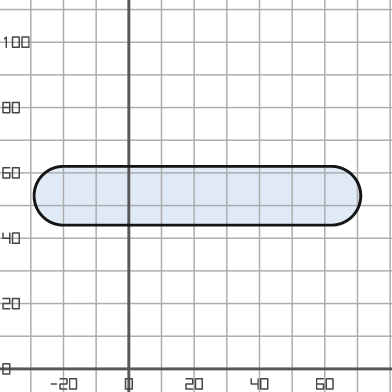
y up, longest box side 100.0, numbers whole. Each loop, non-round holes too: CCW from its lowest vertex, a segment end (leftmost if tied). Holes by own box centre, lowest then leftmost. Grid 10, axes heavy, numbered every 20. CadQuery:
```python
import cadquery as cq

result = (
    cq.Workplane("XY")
    .moveTo(-20.0, 44.0)
    .lineTo(62.0, 44.0)
    .threePointArc((71.0, 53.0), (62.0, 62.0))
    .lineTo(-20.0, 62.0)
    .threePointArc((-29.0, 53.0), (-20.0, 44.0))
    .close()
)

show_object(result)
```